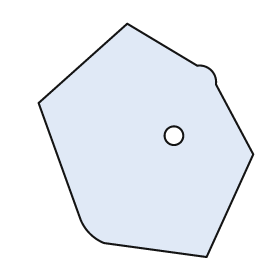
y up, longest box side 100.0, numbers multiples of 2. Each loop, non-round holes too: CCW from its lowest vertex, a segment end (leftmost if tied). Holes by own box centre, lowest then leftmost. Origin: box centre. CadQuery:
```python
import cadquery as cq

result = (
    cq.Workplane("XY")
    .moveTo(26.0, -50.0)
    .lineTo(46.0, -6.0)
    .lineTo(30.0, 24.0)
    .threePointArc((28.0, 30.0), (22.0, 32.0))
    .lineTo(-8.0, 50.0)
    .lineTo(-46.0, 16.0)
    .lineTo(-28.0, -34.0)
    .threePointArc((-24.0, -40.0), (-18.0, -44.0))
    .close()
    .moveTo(12.0, 2.0)
    .circle(4.0)
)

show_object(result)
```